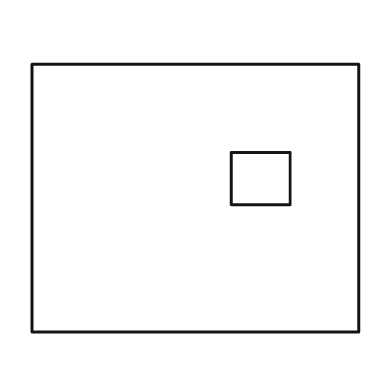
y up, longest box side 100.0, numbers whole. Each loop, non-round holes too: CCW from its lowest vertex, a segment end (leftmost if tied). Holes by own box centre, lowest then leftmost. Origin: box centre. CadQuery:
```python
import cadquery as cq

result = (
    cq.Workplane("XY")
    .moveTo(-50.0, -41.0)
    .lineTo(50.0, -41.0)
    .lineTo(50.0, 41.0)
    .lineTo(-50.0, 41.0)
    .close()
    .moveTo(11.0, -2.0)
    .lineTo(29.0, -2.0)
    .lineTo(29.0, 14.0)
    .lineTo(11.0, 14.0)
    .close()
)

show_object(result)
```